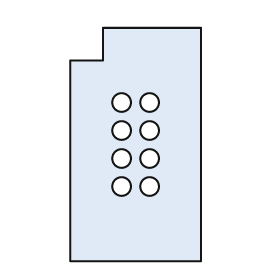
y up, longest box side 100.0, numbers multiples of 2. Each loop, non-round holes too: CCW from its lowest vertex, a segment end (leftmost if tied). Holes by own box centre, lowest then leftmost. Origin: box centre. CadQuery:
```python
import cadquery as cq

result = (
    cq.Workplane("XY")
    .moveTo(-28.0, -50.0)
    .lineTo(28.0, -50.0)
    .lineTo(28.0, 50.0)
    .lineTo(-14.0, 50.0)
    .lineTo(-14.0, 36.0)
    .lineTo(-28.0, 36.0)
    .close()
    .moveTo(-6.0, -18.0)
    .circle(4.0)
    .moveTo(6.0, -18.0)
    .circle(4.0)
    .moveTo(-6.0, -6.0)
    .circle(4.0)
    .moveTo(6.0, -6.0)
    .circle(4.0)
    .moveTo(-6.0, 6.0)
    .circle(4.0)
    .moveTo(6.0, 6.0)
    .circle(4.0)
    .moveTo(-6.0, 18.0)
    .circle(4.0)
    .moveTo(6.0, 18.0)
    .circle(4.0)
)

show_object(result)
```